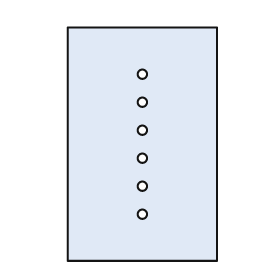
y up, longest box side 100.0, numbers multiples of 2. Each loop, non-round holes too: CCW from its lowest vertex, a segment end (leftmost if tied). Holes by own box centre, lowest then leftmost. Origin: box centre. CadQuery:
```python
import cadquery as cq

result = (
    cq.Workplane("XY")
    .moveTo(-32.0, -50.0)
    .lineTo(32.0, -50.0)
    .lineTo(32.0, 50.0)
    .lineTo(-32.0, 50.0)
    .close()
    .moveTo(0.0, -30.0)
    .circle(2.0)
    .moveTo(0.0, -18.0)
    .circle(2.0)
    .moveTo(0.0, -6.0)
    .circle(2.0)
    .moveTo(0.0, 6.0)
    .circle(2.0)
    .moveTo(0.0, 18.0)
    .circle(2.0)
    .moveTo(0.0, 30.0)
    .circle(2.0)
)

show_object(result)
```